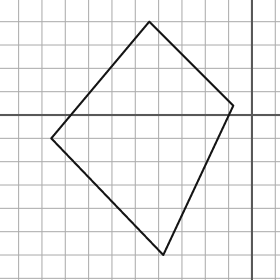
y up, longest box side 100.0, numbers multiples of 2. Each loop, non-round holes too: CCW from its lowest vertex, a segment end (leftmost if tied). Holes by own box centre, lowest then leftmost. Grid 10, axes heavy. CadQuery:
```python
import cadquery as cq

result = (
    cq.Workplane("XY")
    .moveTo(-38.0, -60.0)
    .lineTo(-8.0, 4.0)
    .lineTo(-44.0, 40.0)
    .lineTo(-86.0, -10.0)
    .close()
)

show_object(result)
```